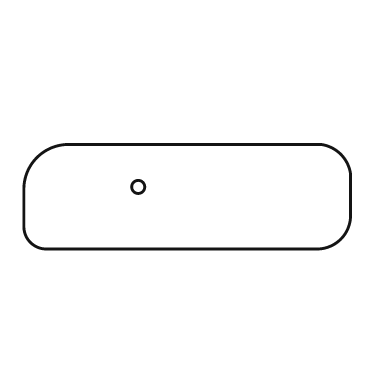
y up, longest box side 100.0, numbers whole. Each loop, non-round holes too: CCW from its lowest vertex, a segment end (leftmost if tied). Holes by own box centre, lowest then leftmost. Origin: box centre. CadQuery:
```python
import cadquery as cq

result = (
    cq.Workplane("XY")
    .moveTo(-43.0, -16.0)
    .lineTo(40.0, -16.0)
    .threePointArc((47.0, -13.0), (50.0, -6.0))
    .lineTo(50.0, 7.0)
    .threePointArc((47.0, 13.0), (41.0, 16.0))
    .lineTo(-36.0, 16.0)
    .threePointArc((-46.0, 12.0), (-50.0, 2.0))
    .lineTo(-50.0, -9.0)
    .threePointArc((-48.0, -14.0), (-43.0, -16.0))
    .close()
    .moveTo(-15.0, 3.0)
    .circle(2.0)
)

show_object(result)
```